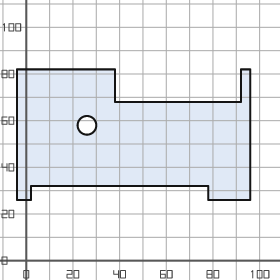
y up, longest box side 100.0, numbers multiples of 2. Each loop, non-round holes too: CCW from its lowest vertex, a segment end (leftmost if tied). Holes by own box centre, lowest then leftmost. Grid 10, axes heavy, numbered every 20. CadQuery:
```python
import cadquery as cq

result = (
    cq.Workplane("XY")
    .moveTo(-4.0, 26.0)
    .lineTo(2.0, 26.0)
    .lineTo(2.0, 32.0)
    .lineTo(78.0, 32.0)
    .lineTo(78.0, 26.0)
    .lineTo(96.0, 26.0)
    .lineTo(96.0, 82.0)
    .lineTo(92.0, 82.0)
    .lineTo(92.0, 68.0)
    .lineTo(38.0, 68.0)
    .lineTo(38.0, 82.0)
    .lineTo(-4.0, 82.0)
    .close()
    .moveTo(26.0, 58.0)
    .circle(4.0)
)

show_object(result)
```